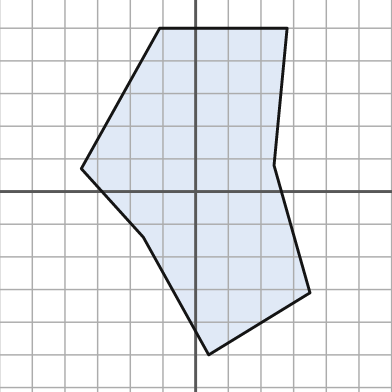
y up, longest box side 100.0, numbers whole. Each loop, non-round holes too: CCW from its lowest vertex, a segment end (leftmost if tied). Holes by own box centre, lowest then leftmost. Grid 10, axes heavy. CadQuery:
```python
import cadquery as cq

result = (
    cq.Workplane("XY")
    .moveTo(4.0, -50.0)
    .lineTo(35.0, -31.0)
    .lineTo(24.0, 8.0)
    .lineTo(28.0, 50.0)
    .lineTo(-11.0, 50.0)
    .lineTo(-35.0, 7.0)
    .lineTo(-16.0, -14.0)
    .close()
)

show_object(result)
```